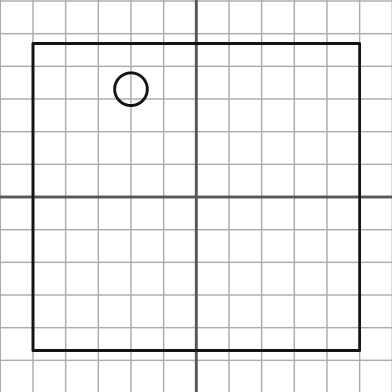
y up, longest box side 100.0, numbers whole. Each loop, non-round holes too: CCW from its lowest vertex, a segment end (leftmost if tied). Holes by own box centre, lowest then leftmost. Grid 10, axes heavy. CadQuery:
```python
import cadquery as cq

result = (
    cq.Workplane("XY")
    .moveTo(-50.0, -47.0)
    .lineTo(50.0, -47.0)
    .lineTo(50.0, 47.0)
    .lineTo(-50.0, 47.0)
    .close()
    .moveTo(-20.0, 33.0)
    .circle(5.0)
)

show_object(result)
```